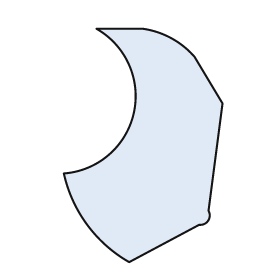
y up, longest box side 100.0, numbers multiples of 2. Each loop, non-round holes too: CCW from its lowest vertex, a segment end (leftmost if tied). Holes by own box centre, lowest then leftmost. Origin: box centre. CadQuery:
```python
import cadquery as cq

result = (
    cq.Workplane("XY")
    .moveTo(-6.0, -50.0)
    .lineTo(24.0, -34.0)
    .threePointArc((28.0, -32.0), (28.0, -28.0))
    .lineTo(34.0, 18.0)
    .lineTo(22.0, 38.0)
    .threePointArc((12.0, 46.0), (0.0, 50.0))
    .lineTo(-20.0, 50.0)
    .threePointArc((-4.0, 14.0), (-34.0, -12.0))
    .threePointArc((-24.0, -34.0), (-6.0, -50.0))
    .close()
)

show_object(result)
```